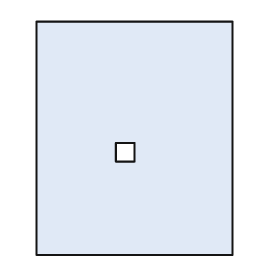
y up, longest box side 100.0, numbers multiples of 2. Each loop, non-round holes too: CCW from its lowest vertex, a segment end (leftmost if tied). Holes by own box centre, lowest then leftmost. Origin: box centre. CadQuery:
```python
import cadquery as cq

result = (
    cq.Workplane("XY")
    .moveTo(-42.0, -50.0)
    .lineTo(42.0, -50.0)
    .lineTo(42.0, 50.0)
    .lineTo(-42.0, 50.0)
    .close()
    .moveTo(-8.0, -10.0)
    .lineTo(0.0, -10.0)
    .lineTo(0.0, -2.0)
    .lineTo(-8.0, -2.0)
    .close()
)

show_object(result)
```